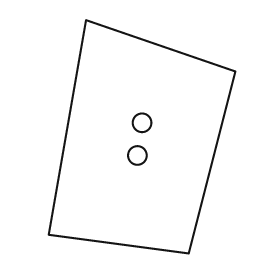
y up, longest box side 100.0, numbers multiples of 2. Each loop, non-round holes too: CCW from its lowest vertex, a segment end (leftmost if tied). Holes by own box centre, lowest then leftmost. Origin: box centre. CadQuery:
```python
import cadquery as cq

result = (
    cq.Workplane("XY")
    .moveTo(20.0, -50.0)
    .lineTo(40.0, 28.0)
    .lineTo(-24.0, 50.0)
    .lineTo(-40.0, -42.0)
    .close()
    .moveTo(-2.0, -8.0)
    .circle(4.0)
    .moveTo(0.0, 6.0)
    .circle(4.0)
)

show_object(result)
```